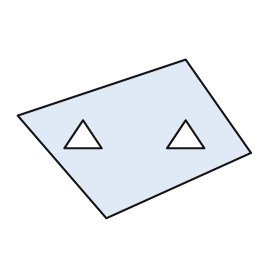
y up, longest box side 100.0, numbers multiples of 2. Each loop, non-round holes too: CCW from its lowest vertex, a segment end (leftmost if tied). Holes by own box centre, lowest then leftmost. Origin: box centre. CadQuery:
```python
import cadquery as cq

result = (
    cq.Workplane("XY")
    .moveTo(-12.0, -34.0)
    .lineTo(50.0, -6.0)
    .lineTo(22.0, 34.0)
    .lineTo(-50.0, 10.0)
    .close()
    .moveTo(-30.0, -4.0)
    .lineTo(-14.0, -4.0)
    .lineTo(-22.0, 8.0)
    .close()
    .moveTo(14.0, -4.0)
    .lineTo(30.0, -4.0)
    .lineTo(22.0, 8.0)
    .close()
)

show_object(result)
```